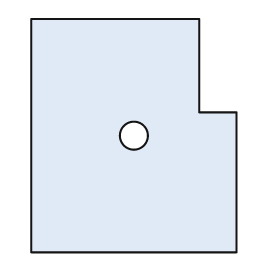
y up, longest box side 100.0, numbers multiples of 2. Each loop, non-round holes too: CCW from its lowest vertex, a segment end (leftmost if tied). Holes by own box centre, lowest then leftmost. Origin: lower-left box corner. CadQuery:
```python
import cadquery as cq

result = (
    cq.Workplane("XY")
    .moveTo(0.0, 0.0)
    .lineTo(88.0, 0.0)
    .lineTo(88.0, 60.0)
    .lineTo(72.0, 60.0)
    .lineTo(72.0, 100.0)
    .lineTo(0.0, 100.0)
    .close()
    .moveTo(44.0, 50.0)
    .circle(6.0)
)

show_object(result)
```